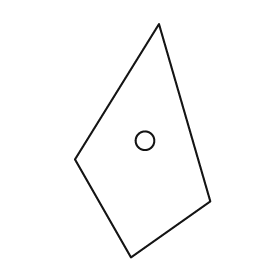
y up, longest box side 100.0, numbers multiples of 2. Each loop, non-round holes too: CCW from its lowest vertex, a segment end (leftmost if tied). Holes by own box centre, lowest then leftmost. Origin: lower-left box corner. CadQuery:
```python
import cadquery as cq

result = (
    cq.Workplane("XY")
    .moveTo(24.0, 0.0)
    .lineTo(58.0, 24.0)
    .lineTo(36.0, 100.0)
    .lineTo(0.0, 42.0)
    .close()
    .moveTo(30.0, 50.0)
    .circle(4.0)
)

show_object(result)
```